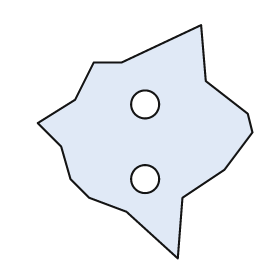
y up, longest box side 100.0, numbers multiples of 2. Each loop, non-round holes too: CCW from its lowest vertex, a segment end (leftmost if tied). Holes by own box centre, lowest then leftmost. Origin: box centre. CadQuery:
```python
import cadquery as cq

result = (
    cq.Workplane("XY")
    .moveTo(14.0, -50.0)
    .lineTo(16.0, -24.0)
    .lineTo(34.0, -12.0)
    .lineTo(46.0, 4.0)
    .lineTo(44.0, 12.0)
    .lineTo(26.0, 26.0)
    .lineTo(24.0, 50.0)
    .lineTo(-10.0, 34.0)
    .lineTo(-22.0, 34.0)
    .lineTo(-30.0, 18.0)
    .lineTo(-46.0, 8.0)
    .lineTo(-36.0, -2.0)
    .lineTo(-32.0, -16.0)
    .lineTo(-24.0, -24.0)
    .lineTo(-8.0, -30.0)
    .close()
    .moveTo(0.0, -16.0)
    .circle(6.0)
    .moveTo(0.0, 16.0)
    .circle(6.0)
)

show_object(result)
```